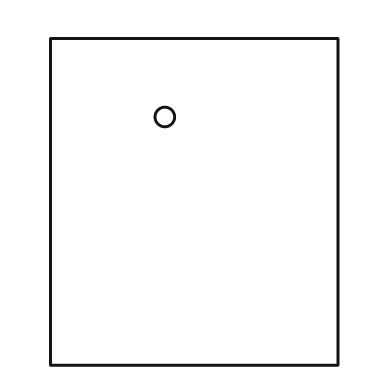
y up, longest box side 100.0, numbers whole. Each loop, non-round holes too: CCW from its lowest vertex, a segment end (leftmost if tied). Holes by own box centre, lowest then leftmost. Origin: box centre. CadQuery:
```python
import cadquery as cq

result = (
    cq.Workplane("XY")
    .moveTo(-44.0, -50.0)
    .lineTo(44.0, -50.0)
    .lineTo(44.0, 50.0)
    .lineTo(-44.0, 50.0)
    .close()
    .moveTo(-9.0, 26.0)
    .circle(3.0)
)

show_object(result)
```